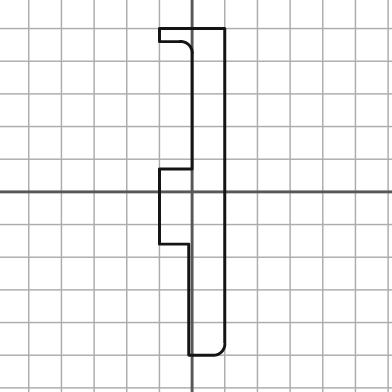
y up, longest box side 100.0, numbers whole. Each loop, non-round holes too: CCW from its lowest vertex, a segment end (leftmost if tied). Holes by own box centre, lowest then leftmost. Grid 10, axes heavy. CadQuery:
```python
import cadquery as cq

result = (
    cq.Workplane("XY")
    .moveTo(-1.0, -50.0)
    .lineTo(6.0, -50.0)
    .threePointArc((9.0, -49.0), (10.0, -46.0))
    .lineTo(10.0, 50.0)
    .lineTo(-10.0, 50.0)
    .lineTo(-10.0, 46.0)
    .lineTo(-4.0, 46.0)
    .threePointArc((-1.0, 45.0), (0.0, 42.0))
    .lineTo(0.0, 7.0)
    .lineTo(-10.0, 7.0)
    .lineTo(-10.0, -16.0)
    .lineTo(-1.0, -16.0)
    .close()
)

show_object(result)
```